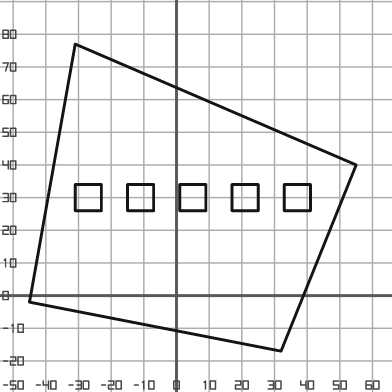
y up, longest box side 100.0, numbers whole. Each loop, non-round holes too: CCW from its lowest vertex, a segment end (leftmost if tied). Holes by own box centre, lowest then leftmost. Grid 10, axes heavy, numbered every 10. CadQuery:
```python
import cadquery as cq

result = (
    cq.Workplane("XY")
    .moveTo(32.0, -17.0)
    .lineTo(55.0, 40.0)
    .lineTo(-31.0, 77.0)
    .lineTo(-45.0, -2.0)
    .close()
    .moveTo(-31.0, 26.0)
    .lineTo(-23.0, 26.0)
    .lineTo(-23.0, 34.0)
    .lineTo(-31.0, 34.0)
    .close()
    .moveTo(-15.0, 26.0)
    .lineTo(-7.0, 26.0)
    .lineTo(-7.0, 34.0)
    .lineTo(-15.0, 34.0)
    .close()
    .moveTo(1.0, 26.0)
    .lineTo(9.0, 26.0)
    .lineTo(9.0, 34.0)
    .lineTo(1.0, 34.0)
    .close()
    .moveTo(17.0, 26.0)
    .lineTo(25.0, 26.0)
    .lineTo(25.0, 34.0)
    .lineTo(17.0, 34.0)
    .close()
    .moveTo(33.0, 26.0)
    .lineTo(41.0, 26.0)
    .lineTo(41.0, 34.0)
    .lineTo(33.0, 34.0)
    .close()
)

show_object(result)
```